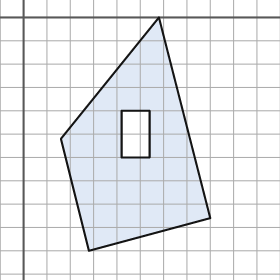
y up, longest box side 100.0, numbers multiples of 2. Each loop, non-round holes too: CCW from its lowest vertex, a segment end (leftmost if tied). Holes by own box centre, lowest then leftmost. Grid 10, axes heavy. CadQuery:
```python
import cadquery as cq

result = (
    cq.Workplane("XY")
    .moveTo(28.0, -100.0)
    .lineTo(80.0, -86.0)
    .lineTo(58.0, 0.0)
    .lineTo(16.0, -52.0)
    .close()
    .moveTo(42.0, -60.0)
    .lineTo(54.0, -60.0)
    .lineTo(54.0, -40.0)
    .lineTo(42.0, -40.0)
    .close()
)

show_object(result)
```